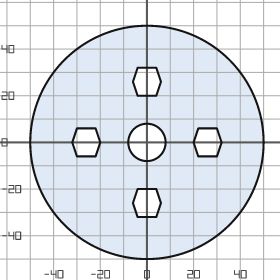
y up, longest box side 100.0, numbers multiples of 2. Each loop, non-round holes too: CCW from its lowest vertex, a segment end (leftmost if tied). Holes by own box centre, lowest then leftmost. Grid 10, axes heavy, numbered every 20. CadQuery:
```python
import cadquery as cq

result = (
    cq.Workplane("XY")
    .moveTo(0.0, 0.0)
    .circle(50.0)
    .moveTo(-4.0, -32.0)
    .lineTo(4.0, -32.0)
    .lineTo(6.0, -26.0)
    .lineTo(4.0, -20.0)
    .lineTo(-4.0, -20.0)
    .lineTo(-6.0, -26.0)
    .close()
    .moveTo(-30.0, -6.0)
    .lineTo(-22.0, -6.0)
    .lineTo(-20.0, 0.0)
    .lineTo(-22.0, 6.0)
    .lineTo(-30.0, 6.0)
    .lineTo(-32.0, 0.0)
    .close()
    .moveTo(0.0, 0.0)
    .circle(8.0)
    .moveTo(22.0, -6.0)
    .lineTo(30.0, -6.0)
    .lineTo(32.0, 0.0)
    .lineTo(30.0, 6.0)
    .lineTo(22.0, 6.0)
    .lineTo(20.0, 0.0)
    .close()
    .moveTo(-4.0, 20.0)
    .lineTo(4.0, 20.0)
    .lineTo(6.0, 26.0)
    .lineTo(4.0, 32.0)
    .lineTo(-4.0, 32.0)
    .lineTo(-6.0, 26.0)
    .close()
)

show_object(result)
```